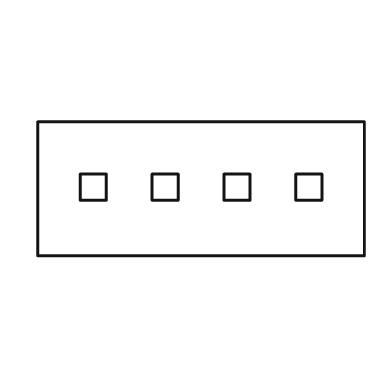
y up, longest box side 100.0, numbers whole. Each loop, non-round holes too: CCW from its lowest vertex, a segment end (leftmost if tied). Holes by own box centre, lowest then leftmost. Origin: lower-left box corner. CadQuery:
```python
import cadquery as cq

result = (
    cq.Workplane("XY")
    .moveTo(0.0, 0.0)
    .lineTo(100.0, 0.0)
    .lineTo(100.0, 41.0)
    .lineTo(0.0, 41.0)
    .close()
    .moveTo(13.0, 17.0)
    .lineTo(21.0, 17.0)
    .lineTo(21.0, 25.0)
    .lineTo(13.0, 25.0)
    .close()
    .moveTo(35.0, 17.0)
    .lineTo(43.0, 17.0)
    .lineTo(43.0, 25.0)
    .lineTo(35.0, 25.0)
    .close()
    .moveTo(57.0, 17.0)
    .lineTo(65.0, 17.0)
    .lineTo(65.0, 25.0)
    .lineTo(57.0, 25.0)
    .close()
    .moveTo(79.0, 17.0)
    .lineTo(87.0, 17.0)
    .lineTo(87.0, 25.0)
    .lineTo(79.0, 25.0)
    .close()
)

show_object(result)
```